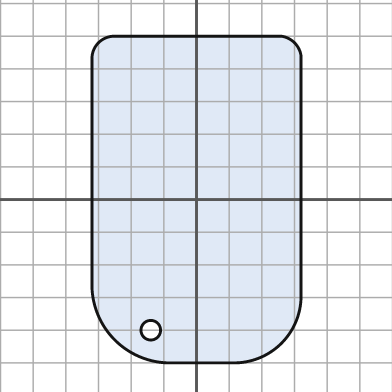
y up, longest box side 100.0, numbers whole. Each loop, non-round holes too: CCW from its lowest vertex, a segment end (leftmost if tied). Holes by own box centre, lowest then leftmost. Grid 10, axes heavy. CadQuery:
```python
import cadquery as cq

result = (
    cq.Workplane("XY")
    .moveTo(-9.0, -50.0)
    .lineTo(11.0, -50.0)
    .threePointArc((26.0, -44.0), (32.0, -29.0))
    .lineTo(32.0, 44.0)
    .threePointArc((30.0, 48.0), (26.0, 50.0))
    .lineTo(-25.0, 50.0)
    .threePointArc((-30.0, 48.0), (-32.0, 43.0))
    .lineTo(-32.0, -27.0)
    .threePointArc((-25.0, -43.0), (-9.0, -50.0))
    .close()
    .moveTo(-14.0, -40.0)
    .circle(3.0)
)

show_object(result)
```